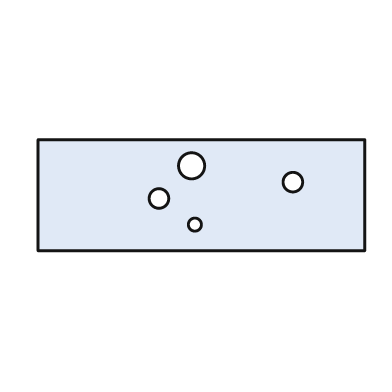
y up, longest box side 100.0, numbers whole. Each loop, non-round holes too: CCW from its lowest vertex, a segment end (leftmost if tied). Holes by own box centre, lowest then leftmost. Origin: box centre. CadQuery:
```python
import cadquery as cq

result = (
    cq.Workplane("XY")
    .moveTo(-50.0, -17.0)
    .lineTo(50.0, -17.0)
    .lineTo(50.0, 17.0)
    .lineTo(-50.0, 17.0)
    .close()
    .moveTo(-2.0, -9.0)
    .circle(2.0)
    .moveTo(-13.0, -1.0)
    .circle(3.0)
    .moveTo(28.0, 4.0)
    .circle(3.0)
    .moveTo(-3.0, 9.0)
    .circle(4.0)
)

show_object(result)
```